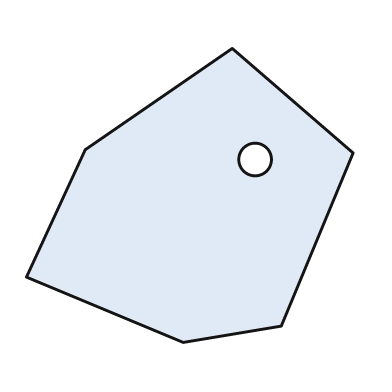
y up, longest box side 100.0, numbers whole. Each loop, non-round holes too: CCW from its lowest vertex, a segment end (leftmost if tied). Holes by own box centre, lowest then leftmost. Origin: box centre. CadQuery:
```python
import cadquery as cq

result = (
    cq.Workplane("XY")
    .moveTo(-2.0, -45.0)
    .lineTo(28.0, -40.0)
    .lineTo(50.0, 13.0)
    .lineTo(13.0, 45.0)
    .lineTo(-32.0, 14.0)
    .lineTo(-50.0, -25.0)
    .close()
    .moveTo(20.0, 11.0)
    .circle(5.0)
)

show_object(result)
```